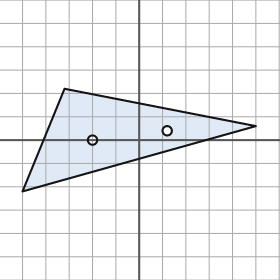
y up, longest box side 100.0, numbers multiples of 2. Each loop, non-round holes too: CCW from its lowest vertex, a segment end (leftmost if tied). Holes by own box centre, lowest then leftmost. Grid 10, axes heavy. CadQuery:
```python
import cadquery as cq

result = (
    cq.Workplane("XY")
    .moveTo(-50.0, -22.0)
    .lineTo(50.0, 6.0)
    .lineTo(-32.0, 22.0)
    .close()
    .moveTo(-20.0, 0.0)
    .circle(2.0)
    .moveTo(12.0, 4.0)
    .circle(2.0)
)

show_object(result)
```